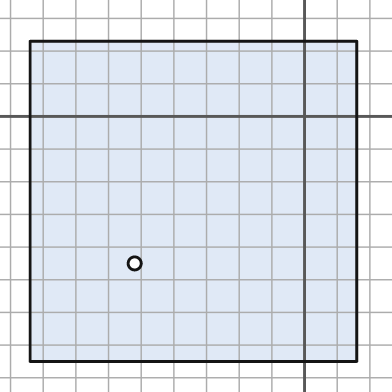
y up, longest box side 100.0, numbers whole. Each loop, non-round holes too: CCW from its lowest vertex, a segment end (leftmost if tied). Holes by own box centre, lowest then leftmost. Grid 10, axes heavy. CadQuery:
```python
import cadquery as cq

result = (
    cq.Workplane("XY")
    .moveTo(-84.0, -75.0)
    .lineTo(16.0, -75.0)
    .lineTo(16.0, 23.0)
    .lineTo(-84.0, 23.0)
    .close()
    .moveTo(-52.0, -45.0)
    .circle(2.0)
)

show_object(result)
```